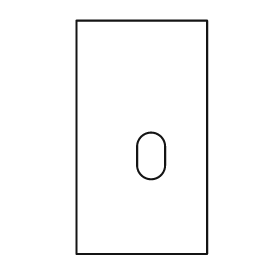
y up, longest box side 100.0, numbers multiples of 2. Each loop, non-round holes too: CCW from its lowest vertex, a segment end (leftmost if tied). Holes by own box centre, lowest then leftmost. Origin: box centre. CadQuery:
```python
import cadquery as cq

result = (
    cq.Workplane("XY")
    .moveTo(-28.0, -50.0)
    .lineTo(28.0, -50.0)
    .lineTo(28.0, 50.0)
    .lineTo(-28.0, 50.0)
    .close()
    .moveTo(-2.0, -12.0)
    .threePointArc((4.0, -18.0), (10.0, -12.0))
    .lineTo(10.0, -4.0)
    .threePointArc((4.0, 2.0), (-2.0, -4.0))
    .close()
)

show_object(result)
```